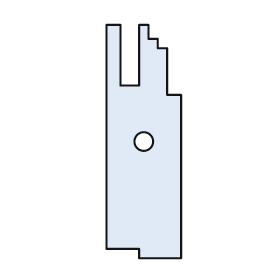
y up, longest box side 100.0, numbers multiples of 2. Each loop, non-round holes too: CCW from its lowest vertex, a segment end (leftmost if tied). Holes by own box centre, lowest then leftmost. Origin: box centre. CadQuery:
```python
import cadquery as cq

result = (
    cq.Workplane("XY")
    .moveTo(-2.0, -50.0)
    .lineTo(16.0, -50.0)
    .lineTo(16.0, 20.0)
    .lineTo(10.0, 20.0)
    .lineTo(10.0, 40.0)
    .lineTo(6.0, 40.0)
    .lineTo(6.0, 44.0)
    .lineTo(2.0, 44.0)
    .lineTo(2.0, 50.0)
    .lineTo(-2.0, 50.0)
    .lineTo(-2.0, 24.0)
    .lineTo(-10.0, 24.0)
    .lineTo(-10.0, 50.0)
    .lineTo(-16.0, 50.0)
    .lineTo(-16.0, -46.0)
    .lineTo(-2.0, -46.0)
    .close()
    .moveTo(0.0, 0.0)
    .circle(4.0)
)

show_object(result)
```